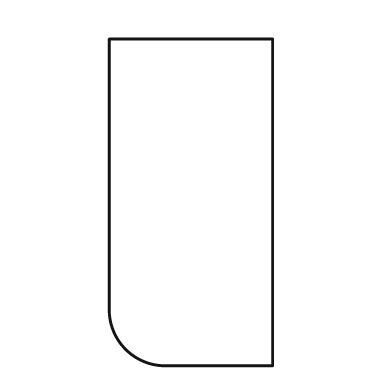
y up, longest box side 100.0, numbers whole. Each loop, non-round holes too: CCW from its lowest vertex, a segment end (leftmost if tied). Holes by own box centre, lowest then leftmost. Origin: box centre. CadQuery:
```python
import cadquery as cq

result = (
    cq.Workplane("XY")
    .moveTo(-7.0, -50.0)
    .lineTo(25.0, -50.0)
    .lineTo(25.0, 50.0)
    .lineTo(-25.0, 50.0)
    .lineTo(-25.0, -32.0)
    .threePointArc((-20.0, -45.0), (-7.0, -50.0))
    .close()
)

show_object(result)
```